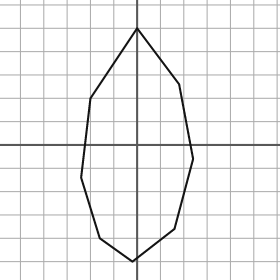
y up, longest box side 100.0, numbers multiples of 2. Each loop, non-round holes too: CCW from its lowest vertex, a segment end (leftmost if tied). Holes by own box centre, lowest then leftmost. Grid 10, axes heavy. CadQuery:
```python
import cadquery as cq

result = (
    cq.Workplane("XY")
    .moveTo(-2.0, -50.0)
    .lineTo(16.0, -36.0)
    .lineTo(24.0, -6.0)
    .lineTo(18.0, 26.0)
    .lineTo(0.0, 50.0)
    .lineTo(-20.0, 20.0)
    .lineTo(-24.0, -14.0)
    .lineTo(-16.0, -40.0)
    .close()
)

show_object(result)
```